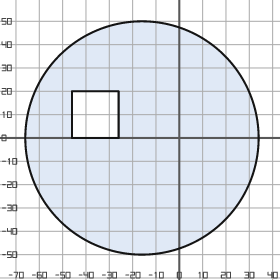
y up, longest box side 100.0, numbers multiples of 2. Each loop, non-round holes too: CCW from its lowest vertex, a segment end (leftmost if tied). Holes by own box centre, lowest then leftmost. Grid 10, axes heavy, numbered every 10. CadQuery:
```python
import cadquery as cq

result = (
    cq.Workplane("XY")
    .moveTo(-16.0, 0.0)
    .circle(50.0)
    .moveTo(-46.0, 0.0)
    .lineTo(-26.0, 0.0)
    .lineTo(-26.0, 20.0)
    .lineTo(-46.0, 20.0)
    .close()
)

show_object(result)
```